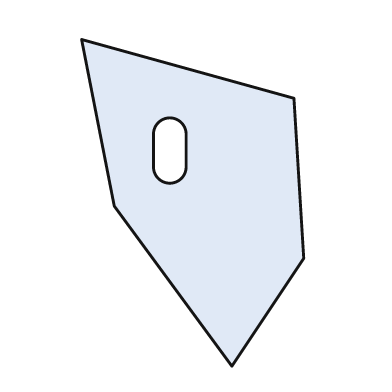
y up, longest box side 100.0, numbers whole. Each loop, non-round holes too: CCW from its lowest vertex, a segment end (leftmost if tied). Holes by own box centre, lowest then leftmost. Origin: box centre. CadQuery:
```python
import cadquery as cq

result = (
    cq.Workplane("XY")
    .moveTo(12.0, -50.0)
    .lineTo(34.0, -17.0)
    .lineTo(31.0, 32.0)
    .lineTo(-34.0, 50.0)
    .lineTo(-24.0, -1.0)
    .close()
    .moveTo(-12.0, 11.0)
    .threePointArc((-7.0, 6.0), (-2.0, 11.0))
    .lineTo(-2.0, 21.0)
    .threePointArc((-7.0, 26.0), (-12.0, 21.0))
    .close()
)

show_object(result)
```